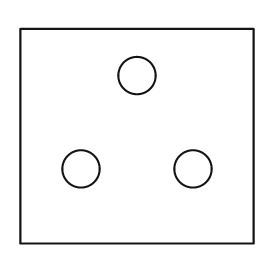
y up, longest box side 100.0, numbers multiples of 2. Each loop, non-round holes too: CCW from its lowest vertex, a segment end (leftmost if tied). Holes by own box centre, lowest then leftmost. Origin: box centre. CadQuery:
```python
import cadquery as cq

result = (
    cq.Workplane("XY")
    .moveTo(-50.0, -46.0)
    .lineTo(50.0, -46.0)
    .lineTo(50.0, 46.0)
    .lineTo(-50.0, 46.0)
    .close()
    .moveTo(-24.0, -14.0)
    .circle(8.0)
    .moveTo(24.0, -14.0)
    .circle(8.0)
    .moveTo(0.0, 26.0)
    .circle(8.0)
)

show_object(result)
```